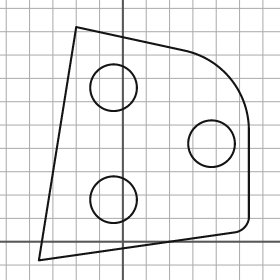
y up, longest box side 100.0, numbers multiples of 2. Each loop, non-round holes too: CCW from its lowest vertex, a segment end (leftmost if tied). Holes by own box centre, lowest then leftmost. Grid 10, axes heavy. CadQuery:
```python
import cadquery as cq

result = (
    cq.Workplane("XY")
    .moveTo(-36.0, -8.0)
    .lineTo(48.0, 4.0)
    .threePointArc((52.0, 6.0), (54.0, 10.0))
    .lineTo(54.0, 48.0)
    .threePointArc((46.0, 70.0), (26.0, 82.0))
    .lineTo(-20.0, 92.0)
    .close()
    .moveTo(-4.0, 18.0)
    .circle(10.0)
    .moveTo(38.0, 42.0)
    .circle(10.0)
    .moveTo(-4.0, 66.0)
    .circle(10.0)
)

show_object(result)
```